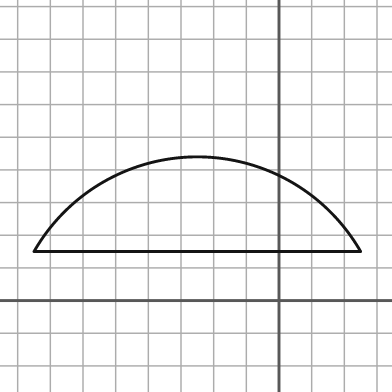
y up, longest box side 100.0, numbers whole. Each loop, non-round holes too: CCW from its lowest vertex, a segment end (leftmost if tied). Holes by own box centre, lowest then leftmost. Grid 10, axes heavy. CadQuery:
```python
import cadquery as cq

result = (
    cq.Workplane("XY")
    .moveTo(-75.0, 15.0)
    .lineTo(25.0, 15.0)
    .threePointArc((-25.0, 44.0), (-75.0, 15.0))
    .close()
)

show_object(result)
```